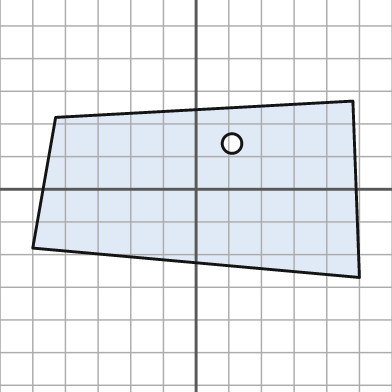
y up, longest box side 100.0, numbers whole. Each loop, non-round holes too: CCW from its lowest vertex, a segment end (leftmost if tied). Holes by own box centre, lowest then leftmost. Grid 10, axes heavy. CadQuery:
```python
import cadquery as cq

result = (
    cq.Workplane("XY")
    .moveTo(50.0, -27.0)
    .lineTo(48.0, 27.0)
    .lineTo(-43.0, 22.0)
    .lineTo(-50.0, -18.0)
    .close()
    .moveTo(11.0, 14.0)
    .circle(3.0)
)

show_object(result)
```